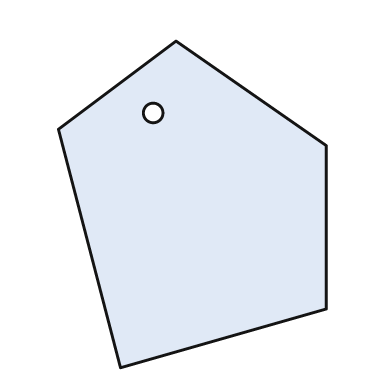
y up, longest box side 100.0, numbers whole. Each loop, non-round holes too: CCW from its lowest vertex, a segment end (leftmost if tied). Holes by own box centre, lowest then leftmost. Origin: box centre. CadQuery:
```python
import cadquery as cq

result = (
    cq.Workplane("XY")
    .moveTo(-22.0, -50.0)
    .lineTo(41.0, -32.0)
    .lineTo(41.0, 18.0)
    .lineTo(-5.0, 50.0)
    .lineTo(-41.0, 23.0)
    .close()
    .moveTo(-12.0, 28.0)
    .circle(3.0)
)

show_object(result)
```